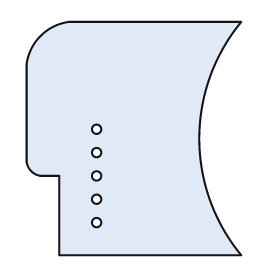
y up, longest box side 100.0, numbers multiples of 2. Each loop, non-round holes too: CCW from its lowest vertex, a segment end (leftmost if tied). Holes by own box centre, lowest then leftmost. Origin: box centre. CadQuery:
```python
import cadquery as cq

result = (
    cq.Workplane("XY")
    .moveTo(-32.0, -50.0)
    .lineTo(46.0, -50.0)
    .threePointArc((28.0, 0.0), (46.0, 50.0))
    .lineTo(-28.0, 50.0)
    .threePointArc((-40.0, 44.0), (-46.0, 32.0))
    .lineTo(-46.0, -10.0)
    .threePointArc((-44.0, -14.0), (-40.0, -16.0))
    .lineTo(-32.0, -16.0)
    .close()
    .moveTo(-16.0, -36.0)
    .circle(2.0)
    .moveTo(-16.0, -26.0)
    .circle(2.0)
    .moveTo(-16.0, -16.0)
    .circle(2.0)
    .moveTo(-16.0, -6.0)
    .circle(2.0)
    .moveTo(-16.0, 4.0)
    .circle(2.0)
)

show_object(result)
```